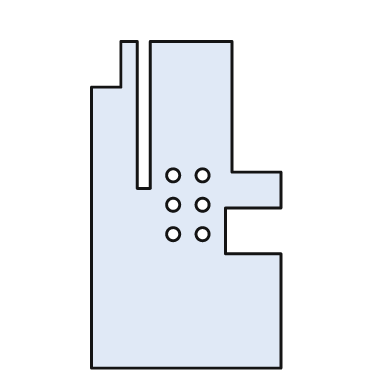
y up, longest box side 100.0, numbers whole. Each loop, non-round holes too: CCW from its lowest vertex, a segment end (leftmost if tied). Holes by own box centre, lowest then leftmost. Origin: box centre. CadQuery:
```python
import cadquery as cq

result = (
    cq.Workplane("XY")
    .moveTo(-29.0, -50.0)
    .lineTo(29.0, -50.0)
    .lineTo(29.0, -15.0)
    .lineTo(12.0, -15.0)
    .lineTo(12.0, -1.0)
    .lineTo(29.0, -1.0)
    .lineTo(29.0, 10.0)
    .lineTo(14.0, 10.0)
    .lineTo(14.0, 50.0)
    .lineTo(-11.0, 50.0)
    .lineTo(-11.0, 5.0)
    .lineTo(-15.0, 5.0)
    .lineTo(-15.0, 50.0)
    .lineTo(-20.0, 50.0)
    .lineTo(-20.0, 36.0)
    .lineTo(-29.0, 36.0)
    .close()
    .moveTo(-4.0, -9.0)
    .circle(2.0)
    .moveTo(5.0, -9.0)
    .circle(2.0)
    .moveTo(-4.0, 0.0)
    .circle(2.0)
    .moveTo(5.0, 0.0)
    .circle(2.0)
    .moveTo(-4.0, 9.0)
    .circle(2.0)
    .moveTo(5.0, 9.0)
    .circle(2.0)
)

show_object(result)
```